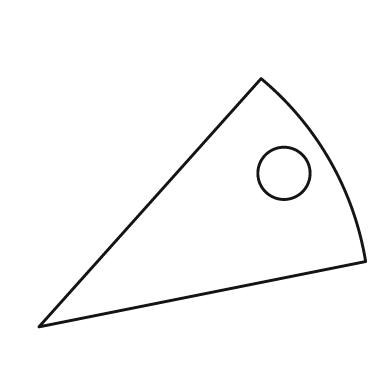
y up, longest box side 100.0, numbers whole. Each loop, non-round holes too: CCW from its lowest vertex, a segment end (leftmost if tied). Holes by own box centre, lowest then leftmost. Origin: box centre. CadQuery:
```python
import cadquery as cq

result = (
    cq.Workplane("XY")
    .moveTo(-50.0, -38.0)
    .lineTo(50.0, -18.0)
    .threePointArc((39.0, 13.0), (18.0, 38.0))
    .close()
    .moveTo(25.0, 9.0)
    .circle(8.0)
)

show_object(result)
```